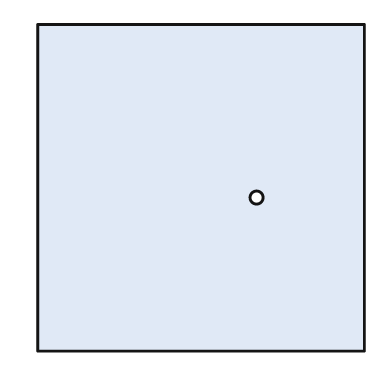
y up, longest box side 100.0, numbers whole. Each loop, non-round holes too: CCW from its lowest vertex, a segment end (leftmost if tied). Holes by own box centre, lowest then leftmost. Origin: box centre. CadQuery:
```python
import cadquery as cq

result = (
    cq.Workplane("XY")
    .moveTo(-50.0, -50.0)
    .lineTo(50.0, -50.0)
    .lineTo(50.0, 50.0)
    .lineTo(-50.0, 50.0)
    .close()
    .moveTo(17.0, -3.0)
    .circle(2.0)
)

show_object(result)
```